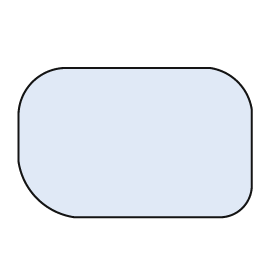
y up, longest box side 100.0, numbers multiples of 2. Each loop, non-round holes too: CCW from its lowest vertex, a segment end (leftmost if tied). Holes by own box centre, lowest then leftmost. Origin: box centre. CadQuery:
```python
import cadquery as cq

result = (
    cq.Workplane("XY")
    .moveTo(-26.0, -32.0)
    .lineTo(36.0, -32.0)
    .threePointArc((46.0, -28.0), (50.0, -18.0))
    .lineTo(50.0, 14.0)
    .threePointArc((44.0, 26.0), (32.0, 32.0))
    .lineTo(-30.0, 32.0)
    .threePointArc((-44.0, 26.0), (-50.0, 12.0))
    .lineTo(-50.0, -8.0)
    .threePointArc((-42.0, -24.0), (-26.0, -32.0))
    .close()
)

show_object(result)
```